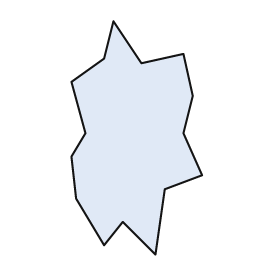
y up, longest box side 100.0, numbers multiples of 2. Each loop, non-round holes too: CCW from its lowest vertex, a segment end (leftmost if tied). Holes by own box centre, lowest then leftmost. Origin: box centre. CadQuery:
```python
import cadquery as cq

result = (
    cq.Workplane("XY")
    .moveTo(8.0, -50.0)
    .lineTo(12.0, -22.0)
    .lineTo(28.0, -16.0)
    .lineTo(20.0, 2.0)
    .lineTo(24.0, 18.0)
    .lineTo(20.0, 36.0)
    .lineTo(2.0, 32.0)
    .lineTo(-10.0, 50.0)
    .lineTo(-14.0, 34.0)
    .lineTo(-28.0, 24.0)
    .lineTo(-22.0, 2.0)
    .lineTo(-28.0, -8.0)
    .lineTo(-26.0, -26.0)
    .lineTo(-14.0, -46.0)
    .lineTo(-6.0, -36.0)
    .close()
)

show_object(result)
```